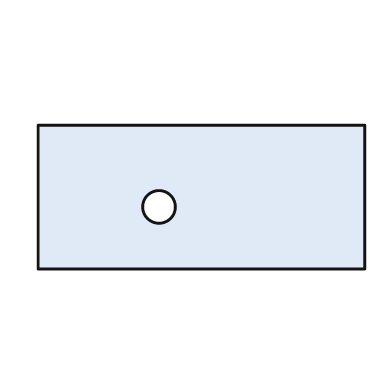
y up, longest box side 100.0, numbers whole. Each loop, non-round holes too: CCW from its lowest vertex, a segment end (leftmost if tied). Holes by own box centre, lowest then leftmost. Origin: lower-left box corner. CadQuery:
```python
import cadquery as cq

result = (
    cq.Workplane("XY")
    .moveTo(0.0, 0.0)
    .lineTo(100.0, 0.0)
    .lineTo(100.0, 44.0)
    .lineTo(0.0, 44.0)
    .close()
    .moveTo(37.0, 19.0)
    .circle(5.0)
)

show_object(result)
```